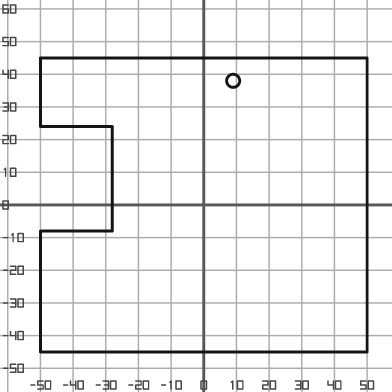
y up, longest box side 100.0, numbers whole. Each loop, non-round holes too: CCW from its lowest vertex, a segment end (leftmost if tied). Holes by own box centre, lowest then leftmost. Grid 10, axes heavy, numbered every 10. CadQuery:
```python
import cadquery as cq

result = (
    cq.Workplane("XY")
    .moveTo(-50.0, -45.0)
    .lineTo(50.0, -45.0)
    .lineTo(50.0, 45.0)
    .lineTo(-50.0, 45.0)
    .lineTo(-50.0, 24.0)
    .lineTo(-28.0, 24.0)
    .lineTo(-28.0, -8.0)
    .lineTo(-50.0, -8.0)
    .close()
    .moveTo(9.0, 38.0)
    .circle(2.0)
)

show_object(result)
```